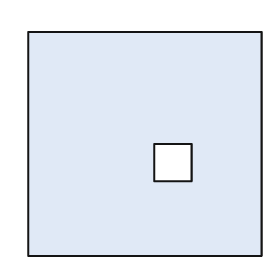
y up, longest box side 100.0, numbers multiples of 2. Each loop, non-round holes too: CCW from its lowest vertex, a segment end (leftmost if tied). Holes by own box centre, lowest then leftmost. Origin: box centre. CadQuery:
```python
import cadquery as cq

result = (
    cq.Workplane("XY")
    .moveTo(-50.0, -48.0)
    .lineTo(50.0, -48.0)
    .lineTo(50.0, 48.0)
    .lineTo(-50.0, 48.0)
    .close()
    .moveTo(4.0, -16.0)
    .lineTo(20.0, -16.0)
    .lineTo(20.0, 0.0)
    .lineTo(4.0, 0.0)
    .close()
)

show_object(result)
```